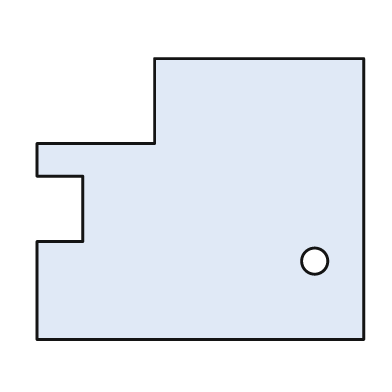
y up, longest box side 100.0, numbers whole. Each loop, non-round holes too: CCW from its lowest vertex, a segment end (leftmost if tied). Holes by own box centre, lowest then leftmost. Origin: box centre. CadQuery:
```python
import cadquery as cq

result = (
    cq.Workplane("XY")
    .moveTo(-50.0, -43.0)
    .lineTo(50.0, -43.0)
    .lineTo(50.0, 43.0)
    .lineTo(-14.0, 43.0)
    .lineTo(-14.0, 17.0)
    .lineTo(-50.0, 17.0)
    .lineTo(-50.0, 7.0)
    .lineTo(-36.0, 7.0)
    .lineTo(-36.0, -13.0)
    .lineTo(-50.0, -13.0)
    .close()
    .moveTo(35.0, -19.0)
    .circle(4.0)
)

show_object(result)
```